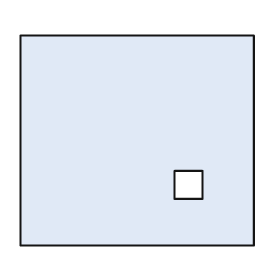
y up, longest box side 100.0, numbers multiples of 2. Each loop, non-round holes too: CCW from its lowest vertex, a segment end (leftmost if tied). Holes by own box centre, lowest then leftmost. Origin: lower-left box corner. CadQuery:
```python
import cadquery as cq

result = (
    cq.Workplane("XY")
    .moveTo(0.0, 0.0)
    .lineTo(100.0, 0.0)
    .lineTo(100.0, 90.0)
    .lineTo(0.0, 90.0)
    .close()
    .moveTo(66.0, 20.0)
    .lineTo(78.0, 20.0)
    .lineTo(78.0, 32.0)
    .lineTo(66.0, 32.0)
    .close()
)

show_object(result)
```